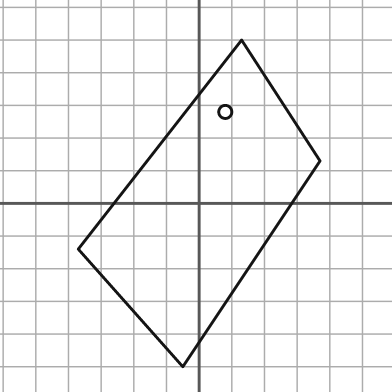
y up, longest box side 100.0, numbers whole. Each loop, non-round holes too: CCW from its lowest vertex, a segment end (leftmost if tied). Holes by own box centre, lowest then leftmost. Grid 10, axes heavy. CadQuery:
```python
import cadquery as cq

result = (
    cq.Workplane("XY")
    .moveTo(-5.0, -50.0)
    .lineTo(37.0, 13.0)
    .lineTo(13.0, 50.0)
    .lineTo(-37.0, -14.0)
    .close()
    .moveTo(8.0, 28.0)
    .circle(2.0)
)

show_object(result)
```